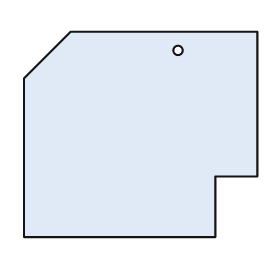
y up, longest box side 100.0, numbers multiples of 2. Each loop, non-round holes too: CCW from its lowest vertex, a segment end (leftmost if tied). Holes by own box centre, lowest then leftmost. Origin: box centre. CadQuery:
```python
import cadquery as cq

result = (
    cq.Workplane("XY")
    .moveTo(-50.0, -44.0)
    .lineTo(32.0, -44.0)
    .lineTo(32.0, -18.0)
    .lineTo(50.0, -18.0)
    .lineTo(50.0, 44.0)
    .lineTo(-30.0, 44.0)
    .lineTo(-50.0, 24.0)
    .close()
    .moveTo(16.0, 36.0)
    .circle(2.0)
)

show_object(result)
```